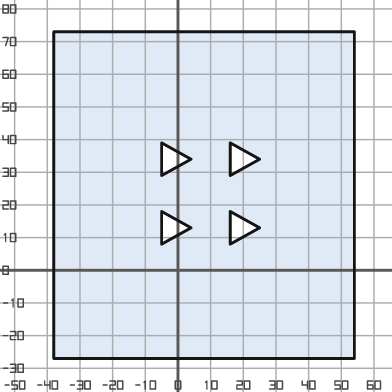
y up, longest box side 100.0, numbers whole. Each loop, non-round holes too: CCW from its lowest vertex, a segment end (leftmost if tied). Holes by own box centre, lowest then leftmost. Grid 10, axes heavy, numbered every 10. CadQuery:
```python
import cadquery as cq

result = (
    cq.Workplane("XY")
    .moveTo(-38.0, -27.0)
    .lineTo(54.0, -27.0)
    .lineTo(54.0, 73.0)
    .lineTo(-38.0, 73.0)
    .close()
    .moveTo(-5.0, 8.0)
    .lineTo(4.0, 13.0)
    .lineTo(-5.0, 18.0)
    .close()
    .moveTo(16.0, 8.0)
    .lineTo(25.0, 13.0)
    .lineTo(16.0, 18.0)
    .close()
    .moveTo(-5.0, 29.0)
    .lineTo(4.0, 34.0)
    .lineTo(-5.0, 39.0)
    .close()
    .moveTo(16.0, 29.0)
    .lineTo(25.0, 34.0)
    .lineTo(16.0, 39.0)
    .close()
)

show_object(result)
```